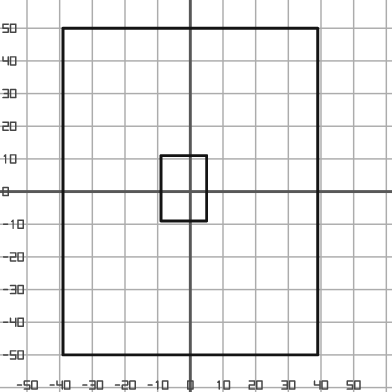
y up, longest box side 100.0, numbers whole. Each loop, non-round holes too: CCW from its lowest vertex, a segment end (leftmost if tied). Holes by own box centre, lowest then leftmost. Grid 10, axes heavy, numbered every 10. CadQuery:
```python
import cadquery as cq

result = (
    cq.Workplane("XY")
    .moveTo(-39.0, -50.0)
    .lineTo(39.0, -50.0)
    .lineTo(39.0, 50.0)
    .lineTo(-39.0, 50.0)
    .close()
    .moveTo(-9.0, -9.0)
    .lineTo(5.0, -9.0)
    .lineTo(5.0, 11.0)
    .lineTo(-9.0, 11.0)
    .close()
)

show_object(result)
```